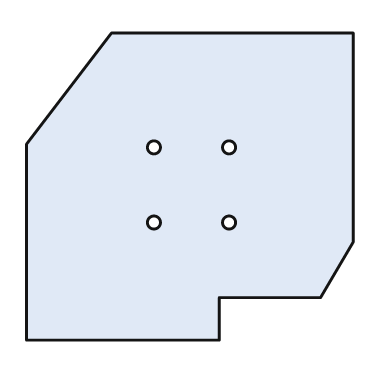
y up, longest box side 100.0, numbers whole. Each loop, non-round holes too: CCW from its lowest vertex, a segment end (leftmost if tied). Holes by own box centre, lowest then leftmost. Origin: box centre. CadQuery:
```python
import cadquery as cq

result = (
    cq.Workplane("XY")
    .moveTo(-50.0, -47.0)
    .lineTo(9.0, -47.0)
    .lineTo(9.0, -34.0)
    .lineTo(40.0, -34.0)
    .lineTo(50.0, -17.0)
    .lineTo(50.0, 47.0)
    .lineTo(-24.0, 47.0)
    .lineTo(-50.0, 13.0)
    .close()
    .moveTo(-11.0, -11.0)
    .circle(2.0)
    .moveTo(12.0, -11.0)
    .circle(2.0)
    .moveTo(-11.0, 12.0)
    .circle(2.0)
    .moveTo(12.0, 12.0)
    .circle(2.0)
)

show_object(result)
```